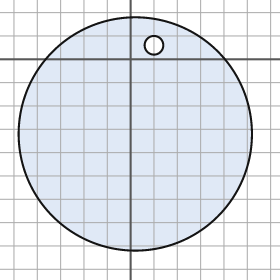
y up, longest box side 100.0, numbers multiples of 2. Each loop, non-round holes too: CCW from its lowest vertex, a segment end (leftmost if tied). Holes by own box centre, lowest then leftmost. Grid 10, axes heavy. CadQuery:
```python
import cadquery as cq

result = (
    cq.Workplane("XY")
    .moveTo(2.0, -32.0)
    .circle(50.0)
    .moveTo(10.0, 6.0)
    .circle(4.0)
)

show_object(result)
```